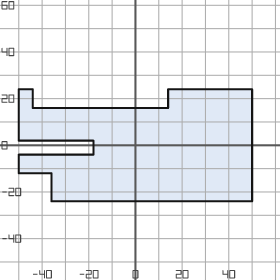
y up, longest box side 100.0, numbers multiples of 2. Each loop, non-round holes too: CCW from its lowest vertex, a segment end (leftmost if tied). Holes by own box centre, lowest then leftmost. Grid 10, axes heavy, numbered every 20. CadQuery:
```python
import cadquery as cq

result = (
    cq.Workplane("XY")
    .moveTo(-36.0, -24.0)
    .lineTo(50.0, -24.0)
    .lineTo(50.0, 24.0)
    .lineTo(14.0, 24.0)
    .lineTo(14.0, 16.0)
    .lineTo(-44.0, 16.0)
    .lineTo(-44.0, 24.0)
    .lineTo(-50.0, 24.0)
    .lineTo(-50.0, 2.0)
    .lineTo(-18.0, 2.0)
    .lineTo(-18.0, -4.0)
    .lineTo(-50.0, -4.0)
    .lineTo(-50.0, -12.0)
    .lineTo(-36.0, -12.0)
    .close()
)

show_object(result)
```